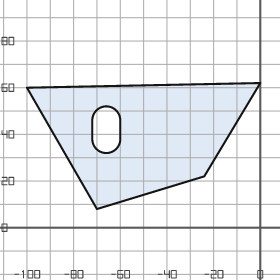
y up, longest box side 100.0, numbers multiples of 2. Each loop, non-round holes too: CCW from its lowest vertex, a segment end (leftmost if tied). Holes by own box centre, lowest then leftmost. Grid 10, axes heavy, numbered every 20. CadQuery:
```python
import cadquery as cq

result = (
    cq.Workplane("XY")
    .moveTo(-70.0, 8.0)
    .lineTo(-24.0, 22.0)
    .lineTo(0.0, 62.0)
    .lineTo(-100.0, 60.0)
    .close()
    .moveTo(-72.0, 38.0)
    .threePointArc((-66.0, 32.0), (-60.0, 38.0))
    .lineTo(-60.0, 46.0)
    .threePointArc((-66.0, 52.0), (-72.0, 46.0))
    .close()
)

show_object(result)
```